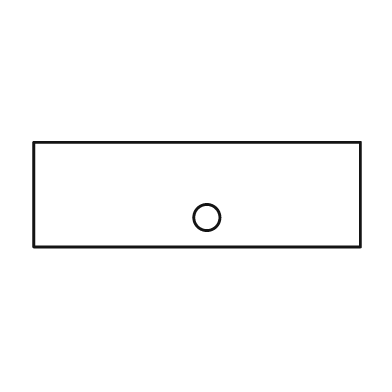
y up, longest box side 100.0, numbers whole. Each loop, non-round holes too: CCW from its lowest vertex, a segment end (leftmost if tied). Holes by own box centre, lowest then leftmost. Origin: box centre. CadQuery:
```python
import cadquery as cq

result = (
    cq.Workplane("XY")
    .moveTo(-50.0, -16.0)
    .lineTo(50.0, -16.0)
    .lineTo(50.0, 16.0)
    .lineTo(-50.0, 16.0)
    .close()
    .moveTo(3.0, -7.0)
    .circle(4.0)
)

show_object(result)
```